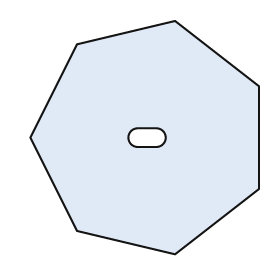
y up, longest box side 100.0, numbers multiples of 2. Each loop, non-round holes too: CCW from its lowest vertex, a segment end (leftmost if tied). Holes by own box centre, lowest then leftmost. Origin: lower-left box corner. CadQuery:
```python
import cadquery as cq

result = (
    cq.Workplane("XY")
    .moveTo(62.0, 0.0)
    .lineTo(98.0, 28.0)
    .lineTo(98.0, 72.0)
    .lineTo(62.0, 100.0)
    .lineTo(20.0, 90.0)
    .lineTo(0.0, 50.0)
    .lineTo(20.0, 10.0)
    .close()
    .moveTo(46.0, 46.0)
    .lineTo(54.0, 46.0)
    .threePointArc((58.0, 50.0), (54.0, 54.0))
    .lineTo(46.0, 54.0)
    .threePointArc((42.0, 50.0), (46.0, 46.0))
    .close()
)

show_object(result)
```